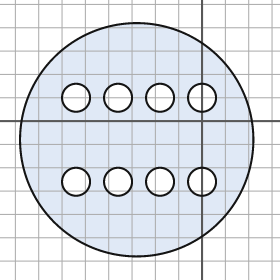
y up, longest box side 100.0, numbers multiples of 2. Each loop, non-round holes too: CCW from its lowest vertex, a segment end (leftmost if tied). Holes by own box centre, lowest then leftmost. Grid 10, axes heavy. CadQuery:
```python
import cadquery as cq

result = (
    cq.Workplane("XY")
    .moveTo(-28.0, -8.0)
    .circle(50.0)
    .moveTo(-54.0, -26.0)
    .circle(6.0)
    .moveTo(-36.0, -26.0)
    .circle(6.0)
    .moveTo(-18.0, -26.0)
    .circle(6.0)
    .moveTo(0.0, -26.0)
    .circle(6.0)
    .moveTo(-54.0, 10.0)
    .circle(6.0)
    .moveTo(-36.0, 10.0)
    .circle(6.0)
    .moveTo(-18.0, 10.0)
    .circle(6.0)
    .moveTo(0.0, 10.0)
    .circle(6.0)
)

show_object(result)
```